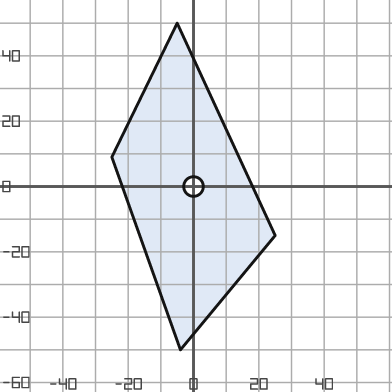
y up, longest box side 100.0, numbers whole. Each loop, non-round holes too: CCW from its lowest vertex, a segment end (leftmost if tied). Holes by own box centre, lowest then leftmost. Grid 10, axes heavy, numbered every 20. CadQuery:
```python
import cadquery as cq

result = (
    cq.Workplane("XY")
    .moveTo(-4.0, -50.0)
    .lineTo(25.0, -15.0)
    .lineTo(-5.0, 50.0)
    .lineTo(-25.0, 9.0)
    .close()
    .moveTo(0.0, 0.0)
    .circle(3.0)
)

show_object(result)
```